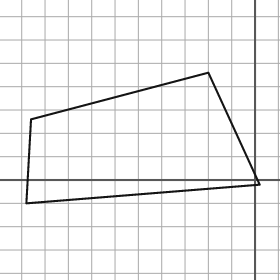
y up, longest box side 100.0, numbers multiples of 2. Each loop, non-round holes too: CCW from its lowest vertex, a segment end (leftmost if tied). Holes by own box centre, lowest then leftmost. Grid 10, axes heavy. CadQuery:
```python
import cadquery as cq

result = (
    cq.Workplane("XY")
    .moveTo(-98.0, -10.0)
    .lineTo(2.0, -2.0)
    .lineTo(-20.0, 46.0)
    .lineTo(-96.0, 26.0)
    .close()
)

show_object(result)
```